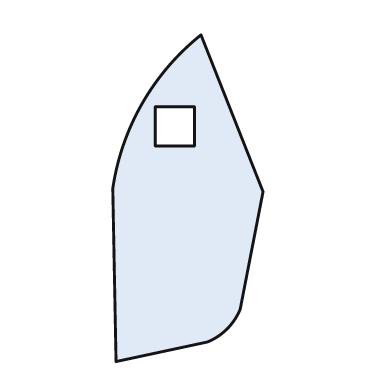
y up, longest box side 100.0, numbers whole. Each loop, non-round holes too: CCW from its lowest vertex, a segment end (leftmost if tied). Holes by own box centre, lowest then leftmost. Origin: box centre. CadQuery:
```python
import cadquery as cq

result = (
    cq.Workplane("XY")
    .moveTo(-22.0, -50.0)
    .lineTo(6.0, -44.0)
    .threePointArc((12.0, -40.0), (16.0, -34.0))
    .lineTo(23.0, 2.0)
    .lineTo(4.0, 50.0)
    .threePointArc((-14.0, 29.0), (-23.0, 3.0))
    .close()
    .moveTo(-10.0, 16.0)
    .lineTo(2.0, 16.0)
    .lineTo(2.0, 28.0)
    .lineTo(-10.0, 28.0)
    .close()
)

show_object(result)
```